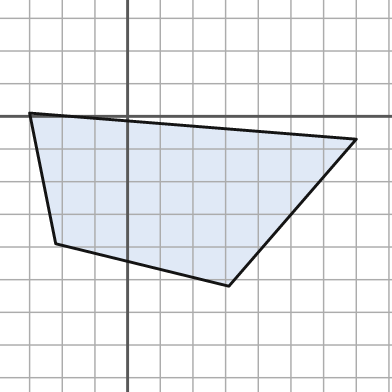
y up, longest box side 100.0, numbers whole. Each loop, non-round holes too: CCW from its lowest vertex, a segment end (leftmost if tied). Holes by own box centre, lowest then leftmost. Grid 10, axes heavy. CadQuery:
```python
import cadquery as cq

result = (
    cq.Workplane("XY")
    .moveTo(31.0, -52.0)
    .lineTo(70.0, -7.0)
    .lineTo(-30.0, 1.0)
    .lineTo(-22.0, -39.0)
    .close()
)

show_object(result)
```